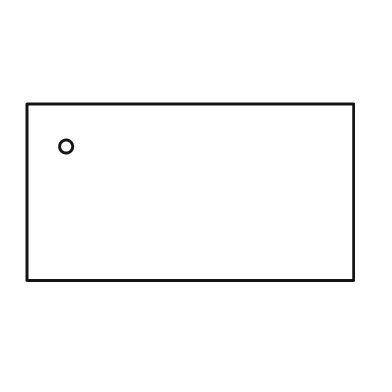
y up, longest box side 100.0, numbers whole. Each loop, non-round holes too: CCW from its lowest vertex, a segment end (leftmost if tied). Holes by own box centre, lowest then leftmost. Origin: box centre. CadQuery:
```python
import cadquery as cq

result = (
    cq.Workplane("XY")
    .moveTo(-50.0, -27.0)
    .lineTo(50.0, -27.0)
    .lineTo(50.0, 27.0)
    .lineTo(-50.0, 27.0)
    .close()
    .moveTo(-38.0, 14.0)
    .circle(2.0)
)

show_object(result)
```